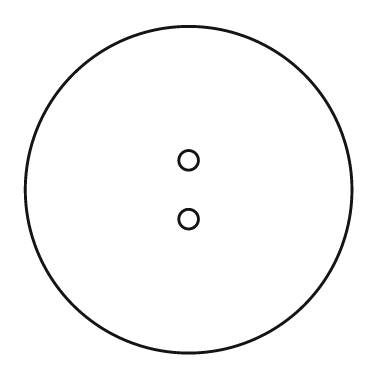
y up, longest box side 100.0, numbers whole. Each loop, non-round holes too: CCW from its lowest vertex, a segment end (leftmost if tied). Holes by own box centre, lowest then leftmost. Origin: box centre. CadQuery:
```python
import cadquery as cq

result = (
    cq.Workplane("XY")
    .moveTo(0.0, 0.0)
    .circle(50.0)
    .moveTo(0.0, -9.0)
    .circle(3.0)
    .moveTo(0.0, 9.0)
    .circle(3.0)
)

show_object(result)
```